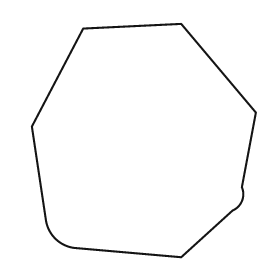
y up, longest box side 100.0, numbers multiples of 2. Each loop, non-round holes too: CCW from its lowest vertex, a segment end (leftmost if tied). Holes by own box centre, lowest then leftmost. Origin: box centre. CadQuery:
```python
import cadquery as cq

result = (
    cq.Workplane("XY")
    .moveTo(16.0, -50.0)
    .lineTo(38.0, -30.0)
    .threePointArc((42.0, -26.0), (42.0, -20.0))
    .lineTo(48.0, 12.0)
    .lineTo(16.0, 50.0)
    .lineTo(-26.0, 48.0)
    .lineTo(-48.0, 6.0)
    .lineTo(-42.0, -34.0)
    .threePointArc((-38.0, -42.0), (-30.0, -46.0))
    .close()
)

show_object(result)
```